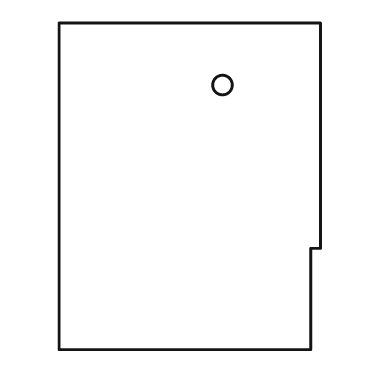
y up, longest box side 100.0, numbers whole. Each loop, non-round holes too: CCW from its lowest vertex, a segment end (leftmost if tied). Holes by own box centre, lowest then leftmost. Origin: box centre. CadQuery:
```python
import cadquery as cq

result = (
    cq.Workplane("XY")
    .moveTo(-40.0, -50.0)
    .lineTo(37.0, -50.0)
    .lineTo(37.0, -19.0)
    .lineTo(40.0, -19.0)
    .lineTo(40.0, 50.0)
    .lineTo(-40.0, 50.0)
    .close()
    .moveTo(10.0, 31.0)
    .circle(3.0)
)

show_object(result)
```